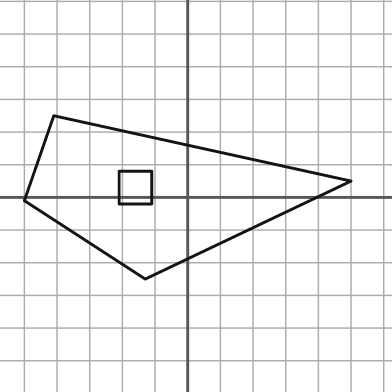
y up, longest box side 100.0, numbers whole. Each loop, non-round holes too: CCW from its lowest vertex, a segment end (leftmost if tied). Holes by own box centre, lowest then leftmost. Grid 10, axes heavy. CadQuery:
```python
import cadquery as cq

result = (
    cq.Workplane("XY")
    .moveTo(-13.0, -25.0)
    .lineTo(50.0, 5.0)
    .lineTo(-41.0, 25.0)
    .lineTo(-50.0, -1.0)
    .close()
    .moveTo(-21.0, -2.0)
    .lineTo(-11.0, -2.0)
    .lineTo(-11.0, 8.0)
    .lineTo(-21.0, 8.0)
    .close()
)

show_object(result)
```